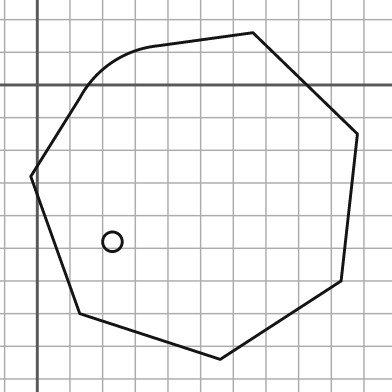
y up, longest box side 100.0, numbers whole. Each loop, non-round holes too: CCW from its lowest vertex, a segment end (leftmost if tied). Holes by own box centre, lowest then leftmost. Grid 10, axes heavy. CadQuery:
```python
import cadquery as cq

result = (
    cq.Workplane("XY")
    .moveTo(56.0, -84.0)
    .lineTo(93.0, -60.0)
    .lineTo(98.0, -15.0)
    .lineTo(66.0, 16.0)
    .lineTo(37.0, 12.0)
    .threePointArc((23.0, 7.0), (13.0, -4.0))
    .lineTo(-2.0, -28.0)
    .lineTo(13.0, -70.0)
    .close()
    .moveTo(23.0, -48.0)
    .circle(3.0)
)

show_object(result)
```